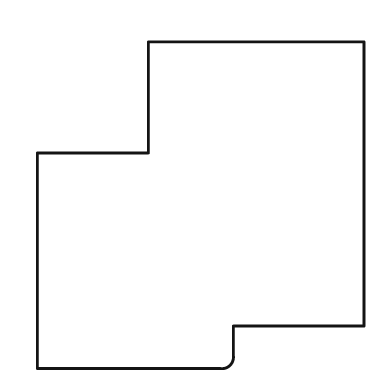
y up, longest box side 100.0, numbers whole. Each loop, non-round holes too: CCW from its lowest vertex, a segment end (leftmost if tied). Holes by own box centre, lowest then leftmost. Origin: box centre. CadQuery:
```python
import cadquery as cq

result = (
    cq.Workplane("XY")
    .moveTo(-50.0, -50.0)
    .lineTo(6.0, -50.0)
    .threePointArc((9.0, -49.0), (10.0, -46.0))
    .lineTo(10.0, -37.0)
    .lineTo(50.0, -37.0)
    .lineTo(50.0, 50.0)
    .lineTo(-16.0, 50.0)
    .lineTo(-16.0, 16.0)
    .lineTo(-50.0, 16.0)
    .close()
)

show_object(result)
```